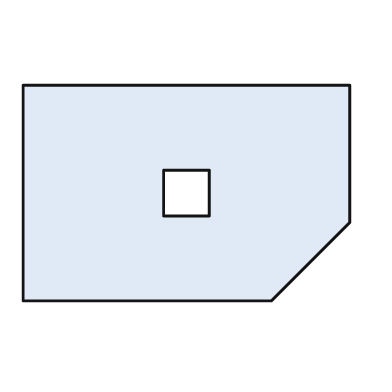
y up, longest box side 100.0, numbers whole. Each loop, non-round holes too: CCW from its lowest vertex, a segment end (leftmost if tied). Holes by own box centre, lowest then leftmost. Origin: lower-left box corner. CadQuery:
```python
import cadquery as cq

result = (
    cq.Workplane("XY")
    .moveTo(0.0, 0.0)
    .lineTo(76.0, 0.0)
    .lineTo(100.0, 24.0)
    .lineTo(100.0, 66.0)
    .lineTo(0.0, 66.0)
    .close()
    .moveTo(43.0, 26.0)
    .lineTo(57.0, 26.0)
    .lineTo(57.0, 40.0)
    .lineTo(43.0, 40.0)
    .close()
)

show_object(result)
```